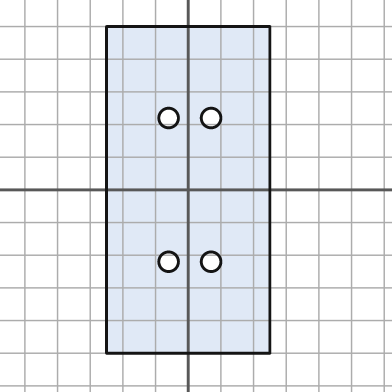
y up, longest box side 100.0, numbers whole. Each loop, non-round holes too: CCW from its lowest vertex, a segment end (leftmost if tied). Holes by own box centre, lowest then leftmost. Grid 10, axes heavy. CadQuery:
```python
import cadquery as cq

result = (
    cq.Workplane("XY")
    .moveTo(-25.0, -50.0)
    .lineTo(25.0, -50.0)
    .lineTo(25.0, 50.0)
    .lineTo(-25.0, 50.0)
    .close()
    .moveTo(-6.0, -22.0)
    .circle(3.0)
    .moveTo(7.0, -22.0)
    .circle(3.0)
    .moveTo(-6.0, 22.0)
    .circle(3.0)
    .moveTo(7.0, 22.0)
    .circle(3.0)
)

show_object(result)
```